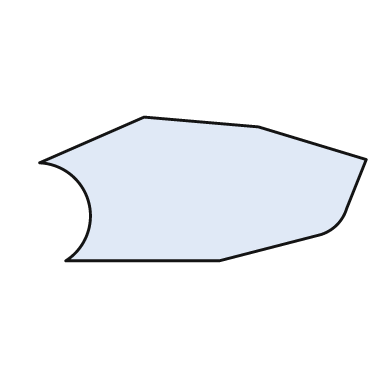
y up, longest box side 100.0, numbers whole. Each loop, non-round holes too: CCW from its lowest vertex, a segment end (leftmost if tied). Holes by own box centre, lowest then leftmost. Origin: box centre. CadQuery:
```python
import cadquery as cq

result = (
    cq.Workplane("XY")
    .moveTo(-42.0, -22.0)
    .lineTo(5.0, -22.0)
    .lineTo(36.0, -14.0)
    .threePointArc((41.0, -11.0), (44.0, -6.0))
    .lineTo(50.0, 9.0)
    .lineTo(17.0, 19.0)
    .lineTo(-18.0, 22.0)
    .lineTo(-50.0, 8.0)
    .threePointArc((-35.0, -4.0), (-42.0, -22.0))
    .close()
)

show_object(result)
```